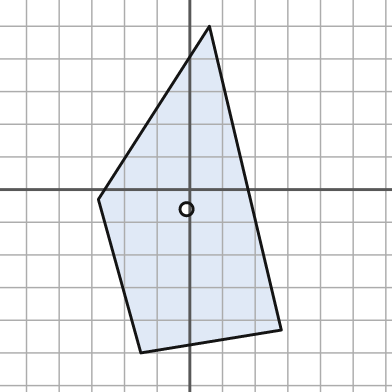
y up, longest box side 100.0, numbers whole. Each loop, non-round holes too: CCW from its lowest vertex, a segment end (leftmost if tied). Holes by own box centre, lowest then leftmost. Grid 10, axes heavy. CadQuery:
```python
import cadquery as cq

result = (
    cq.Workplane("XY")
    .moveTo(-15.0, -50.0)
    .lineTo(28.0, -43.0)
    .lineTo(6.0, 50.0)
    .lineTo(-28.0, -3.0)
    .close()
    .moveTo(-1.0, -6.0)
    .circle(2.0)
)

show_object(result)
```